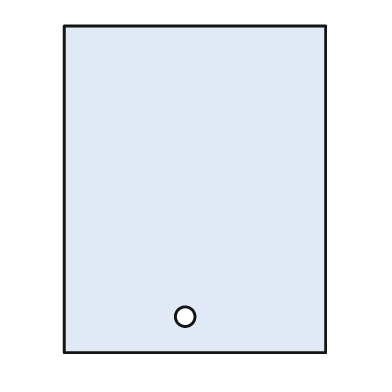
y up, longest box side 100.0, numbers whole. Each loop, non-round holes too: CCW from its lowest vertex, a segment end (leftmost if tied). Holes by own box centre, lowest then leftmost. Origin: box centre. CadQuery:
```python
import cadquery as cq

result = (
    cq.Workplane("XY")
    .moveTo(-40.0, -50.0)
    .lineTo(40.0, -50.0)
    .lineTo(40.0, 50.0)
    .lineTo(-40.0, 50.0)
    .close()
    .moveTo(-3.0, -39.0)
    .circle(3.0)
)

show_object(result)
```